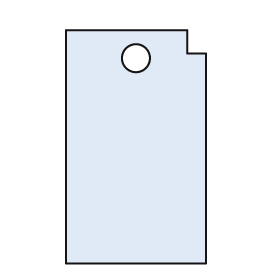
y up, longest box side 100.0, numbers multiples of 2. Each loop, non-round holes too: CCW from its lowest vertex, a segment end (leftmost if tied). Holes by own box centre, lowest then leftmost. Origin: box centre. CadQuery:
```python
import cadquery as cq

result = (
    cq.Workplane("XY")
    .moveTo(-30.0, -50.0)
    .lineTo(30.0, -50.0)
    .lineTo(30.0, 40.0)
    .lineTo(22.0, 40.0)
    .lineTo(22.0, 50.0)
    .lineTo(-30.0, 50.0)
    .close()
    .moveTo(0.0, 38.0)
    .circle(6.0)
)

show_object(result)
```